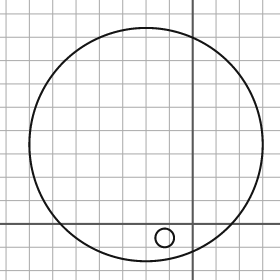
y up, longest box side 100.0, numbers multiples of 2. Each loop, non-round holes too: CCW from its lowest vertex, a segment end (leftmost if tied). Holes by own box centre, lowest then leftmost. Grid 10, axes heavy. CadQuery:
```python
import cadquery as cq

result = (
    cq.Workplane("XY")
    .moveTo(-20.0, 34.0)
    .circle(50.0)
    .moveTo(-12.0, -6.0)
    .circle(4.0)
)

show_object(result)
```